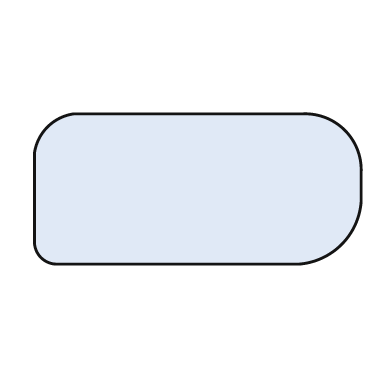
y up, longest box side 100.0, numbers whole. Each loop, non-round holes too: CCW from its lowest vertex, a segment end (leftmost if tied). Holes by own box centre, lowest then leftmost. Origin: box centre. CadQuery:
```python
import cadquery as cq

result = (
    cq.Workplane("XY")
    .moveTo(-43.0, -23.0)
    .lineTo(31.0, -23.0)
    .threePointArc((44.0, -17.0), (50.0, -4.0))
    .lineTo(50.0, 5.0)
    .threePointArc((45.0, 18.0), (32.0, 23.0))
    .lineTo(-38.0, 23.0)
    .threePointArc((-46.0, 19.0), (-50.0, 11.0))
    .lineTo(-50.0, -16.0)
    .threePointArc((-48.0, -21.0), (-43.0, -23.0))
    .close()
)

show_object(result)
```